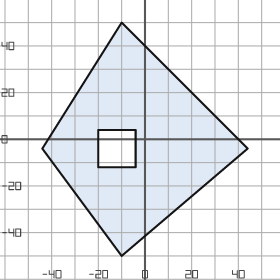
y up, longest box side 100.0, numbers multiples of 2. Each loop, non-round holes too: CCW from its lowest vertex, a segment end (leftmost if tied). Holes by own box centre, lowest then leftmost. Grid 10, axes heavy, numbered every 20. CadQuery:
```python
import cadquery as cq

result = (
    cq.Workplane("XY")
    .moveTo(-10.0, -50.0)
    .lineTo(44.0, -4.0)
    .lineTo(-10.0, 50.0)
    .lineTo(-44.0, -4.0)
    .close()
    .moveTo(-20.0, -12.0)
    .lineTo(-4.0, -12.0)
    .lineTo(-4.0, 4.0)
    .lineTo(-20.0, 4.0)
    .close()
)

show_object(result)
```